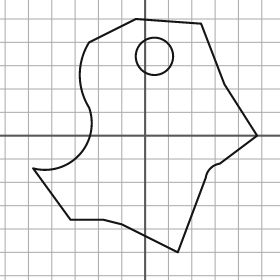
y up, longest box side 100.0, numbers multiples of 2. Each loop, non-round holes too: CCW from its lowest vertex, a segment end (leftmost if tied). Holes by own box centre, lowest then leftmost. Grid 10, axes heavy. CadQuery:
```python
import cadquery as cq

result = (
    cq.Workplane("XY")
    .moveTo(14.0, -50.0)
    .lineTo(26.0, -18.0)
    .threePointArc((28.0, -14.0), (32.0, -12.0))
    .lineTo(48.0, 0.0)
    .lineTo(34.0, 22.0)
    .lineTo(24.0, 48.0)
    .lineTo(-4.0, 50.0)
    .lineTo(-24.0, 40.0)
    .threePointArc((-28.0, 26.0), (-24.0, 12.0))
    .threePointArc((-28.0, -8.0), (-48.0, -14.0))
    .lineTo(-32.0, -36.0)
    .lineTo(-18.0, -36.0)
    .lineTo(-10.0, -38.0)
    .close()
    .moveTo(4.0, 34.0)
    .circle(8.0)
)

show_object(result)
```